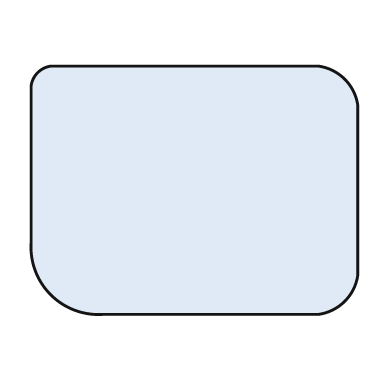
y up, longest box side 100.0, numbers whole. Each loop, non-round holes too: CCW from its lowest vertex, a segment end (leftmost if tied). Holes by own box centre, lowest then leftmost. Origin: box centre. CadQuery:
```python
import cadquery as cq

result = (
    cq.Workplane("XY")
    .moveTo(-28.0, -38.0)
    .lineTo(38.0, -38.0)
    .threePointArc((46.0, -34.0), (50.0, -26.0))
    .lineTo(50.0, 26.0)
    .threePointArc((46.0, 34.0), (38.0, 38.0))
    .lineTo(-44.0, 38.0)
    .threePointArc((-48.0, 36.0), (-50.0, 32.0))
    .lineTo(-50.0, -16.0)
    .threePointArc((-44.0, -32.0), (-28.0, -38.0))
    .close()
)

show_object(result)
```